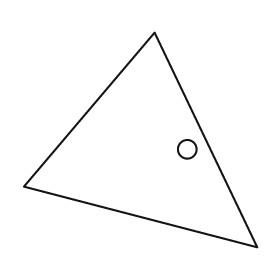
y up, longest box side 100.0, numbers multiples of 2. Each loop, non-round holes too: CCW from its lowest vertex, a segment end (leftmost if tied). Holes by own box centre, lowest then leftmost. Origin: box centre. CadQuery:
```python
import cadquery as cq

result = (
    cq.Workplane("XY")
    .moveTo(50.0, -46.0)
    .lineTo(6.0, 46.0)
    .lineTo(-50.0, -20.0)
    .close()
    .moveTo(20.0, -4.0)
    .circle(4.0)
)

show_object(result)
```